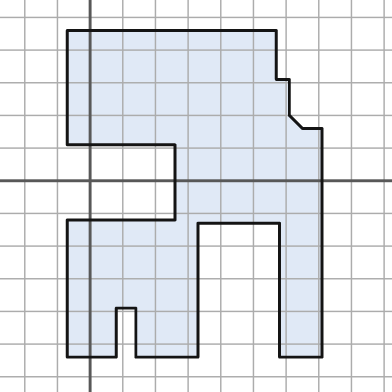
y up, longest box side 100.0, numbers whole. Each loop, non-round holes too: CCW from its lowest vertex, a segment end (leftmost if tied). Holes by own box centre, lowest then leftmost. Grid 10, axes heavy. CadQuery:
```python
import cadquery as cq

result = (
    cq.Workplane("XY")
    .moveTo(-7.0, -54.0)
    .lineTo(8.0, -54.0)
    .lineTo(8.0, -39.0)
    .lineTo(14.0, -39.0)
    .lineTo(14.0, -54.0)
    .lineTo(33.0, -54.0)
    .lineTo(33.0, -13.0)
    .lineTo(58.0, -13.0)
    .lineTo(58.0, -54.0)
    .lineTo(71.0, -54.0)
    .lineTo(71.0, 16.0)
    .lineTo(65.0, 16.0)
    .lineTo(61.0, 20.0)
    .lineTo(61.0, 31.0)
    .lineTo(57.0, 31.0)
    .lineTo(57.0, 46.0)
    .lineTo(-7.0, 46.0)
    .lineTo(-7.0, 11.0)
    .lineTo(26.0, 11.0)
    .lineTo(26.0, -12.0)
    .lineTo(-7.0, -12.0)
    .close()
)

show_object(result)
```